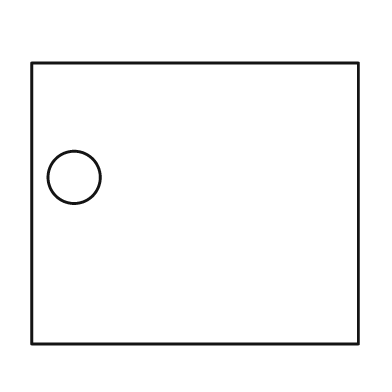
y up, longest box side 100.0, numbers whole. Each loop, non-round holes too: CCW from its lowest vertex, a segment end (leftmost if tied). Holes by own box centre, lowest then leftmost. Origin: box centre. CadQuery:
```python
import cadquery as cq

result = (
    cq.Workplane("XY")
    .moveTo(-50.0, -43.0)
    .lineTo(50.0, -43.0)
    .lineTo(50.0, 43.0)
    .lineTo(-50.0, 43.0)
    .close()
    .moveTo(-37.0, 8.0)
    .circle(8.0)
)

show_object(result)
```